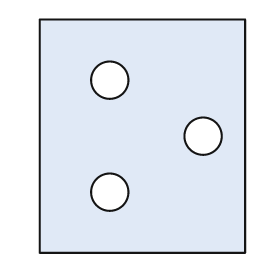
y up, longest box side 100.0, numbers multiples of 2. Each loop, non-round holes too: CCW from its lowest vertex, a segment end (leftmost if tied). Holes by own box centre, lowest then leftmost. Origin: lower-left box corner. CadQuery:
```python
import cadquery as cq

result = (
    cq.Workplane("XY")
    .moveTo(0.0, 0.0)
    .lineTo(88.0, 0.0)
    .lineTo(88.0, 100.0)
    .lineTo(0.0, 100.0)
    .close()
    .moveTo(30.0, 26.0)
    .circle(8.0)
    .moveTo(70.0, 50.0)
    .circle(8.0)
    .moveTo(30.0, 74.0)
    .circle(8.0)
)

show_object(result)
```